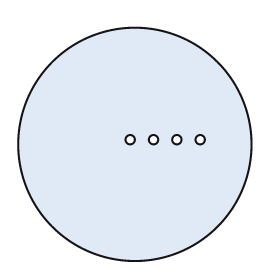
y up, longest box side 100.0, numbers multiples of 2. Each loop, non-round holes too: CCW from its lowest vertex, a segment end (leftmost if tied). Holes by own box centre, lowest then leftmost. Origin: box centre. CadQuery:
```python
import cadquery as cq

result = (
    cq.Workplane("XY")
    .moveTo(0.0, 0.0)
    .circle(50.0)
    .moveTo(-2.0, 2.0)
    .circle(2.0)
    .moveTo(8.0, 2.0)
    .circle(2.0)
    .moveTo(18.0, 2.0)
    .circle(2.0)
    .moveTo(28.0, 2.0)
    .circle(2.0)
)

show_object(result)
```